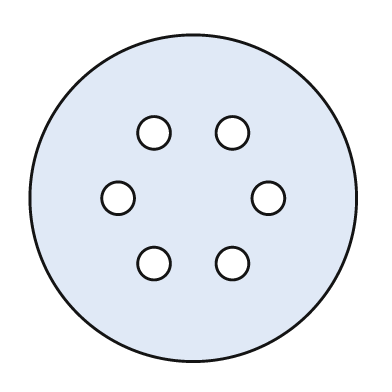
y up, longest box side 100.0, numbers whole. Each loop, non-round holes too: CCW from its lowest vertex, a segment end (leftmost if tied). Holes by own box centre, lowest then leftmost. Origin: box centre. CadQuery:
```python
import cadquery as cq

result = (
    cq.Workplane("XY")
    .moveTo(0.0, 0.0)
    .circle(50.0)
    .moveTo(-12.0, -20.0)
    .circle(5.0)
    .moveTo(12.0, -20.0)
    .circle(5.0)
    .moveTo(-23.0, 0.0)
    .circle(5.0)
    .moveTo(23.0, 0.0)
    .circle(5.0)
    .moveTo(-12.0, 20.0)
    .circle(5.0)
    .moveTo(12.0, 20.0)
    .circle(5.0)
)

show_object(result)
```